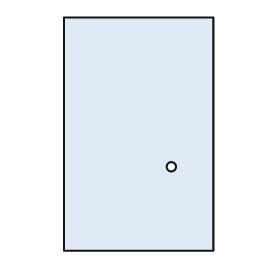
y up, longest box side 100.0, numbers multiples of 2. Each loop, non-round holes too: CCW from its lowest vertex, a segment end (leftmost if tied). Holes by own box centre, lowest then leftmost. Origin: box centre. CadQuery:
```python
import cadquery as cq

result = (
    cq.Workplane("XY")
    .moveTo(-32.0, -50.0)
    .lineTo(32.0, -50.0)
    .lineTo(32.0, 50.0)
    .lineTo(-32.0, 50.0)
    .close()
    .moveTo(14.0, -14.0)
    .circle(2.0)
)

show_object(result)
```